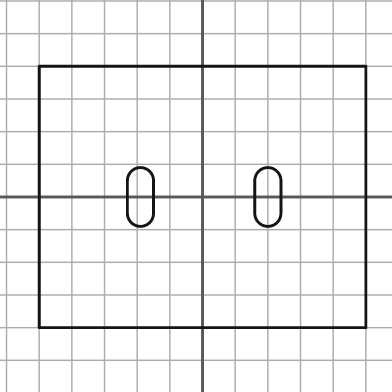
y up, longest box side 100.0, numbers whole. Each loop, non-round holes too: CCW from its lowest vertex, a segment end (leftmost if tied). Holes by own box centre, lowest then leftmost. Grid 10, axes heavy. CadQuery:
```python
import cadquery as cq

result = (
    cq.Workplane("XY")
    .moveTo(-50.0, -40.0)
    .lineTo(50.0, -40.0)
    .lineTo(50.0, 40.0)
    .lineTo(-50.0, 40.0)
    .close()
    .moveTo(-23.0, -5.0)
    .threePointArc((-19.0, -9.0), (-15.0, -5.0))
    .lineTo(-15.0, 5.0)
    .threePointArc((-19.0, 9.0), (-23.0, 5.0))
    .close()
    .moveTo(16.0, -5.0)
    .threePointArc((20.0, -9.0), (24.0, -5.0))
    .lineTo(24.0, 5.0)
    .threePointArc((20.0, 9.0), (16.0, 5.0))
    .close()
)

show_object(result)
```